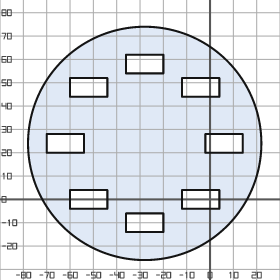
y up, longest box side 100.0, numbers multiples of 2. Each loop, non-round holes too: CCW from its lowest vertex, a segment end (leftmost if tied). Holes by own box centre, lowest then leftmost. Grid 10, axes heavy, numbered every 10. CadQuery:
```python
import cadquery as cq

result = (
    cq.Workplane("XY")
    .moveTo(-28.0, 24.0)
    .circle(50.0)
    .moveTo(-36.0, -14.0)
    .lineTo(-20.0, -14.0)
    .lineTo(-20.0, -6.0)
    .lineTo(-36.0, -6.0)
    .close()
    .moveTo(-60.0, -4.0)
    .lineTo(-44.0, -4.0)
    .lineTo(-44.0, 4.0)
    .lineTo(-60.0, 4.0)
    .close()
    .moveTo(-12.0, -4.0)
    .lineTo(4.0, -4.0)
    .lineTo(4.0, 4.0)
    .lineTo(-12.0, 4.0)
    .close()
    .moveTo(-70.0, 20.0)
    .lineTo(-54.0, 20.0)
    .lineTo(-54.0, 28.0)
    .lineTo(-70.0, 28.0)
    .close()
    .moveTo(-2.0, 20.0)
    .lineTo(14.0, 20.0)
    .lineTo(14.0, 28.0)
    .lineTo(-2.0, 28.0)
    .close()
    .moveTo(-60.0, 44.0)
    .lineTo(-44.0, 44.0)
    .lineTo(-44.0, 52.0)
    .lineTo(-60.0, 52.0)
    .close()
    .moveTo(-12.0, 44.0)
    .lineTo(4.0, 44.0)
    .lineTo(4.0, 52.0)
    .lineTo(-12.0, 52.0)
    .close()
    .moveTo(-36.0, 54.0)
    .lineTo(-20.0, 54.0)
    .lineTo(-20.0, 62.0)
    .lineTo(-36.0, 62.0)
    .close()
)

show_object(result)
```